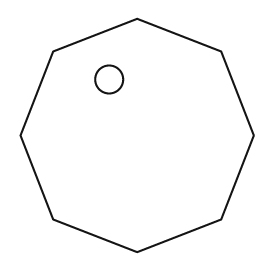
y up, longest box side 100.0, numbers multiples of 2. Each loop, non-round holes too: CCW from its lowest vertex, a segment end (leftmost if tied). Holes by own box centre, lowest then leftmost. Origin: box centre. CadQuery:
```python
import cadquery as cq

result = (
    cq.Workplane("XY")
    .moveTo(0.0, -50.0)
    .lineTo(36.0, -36.0)
    .lineTo(50.0, 0.0)
    .lineTo(36.0, 36.0)
    .lineTo(0.0, 50.0)
    .lineTo(-36.0, 36.0)
    .lineTo(-50.0, 0.0)
    .lineTo(-36.0, -36.0)
    .close()
    .moveTo(-12.0, 24.0)
    .circle(6.0)
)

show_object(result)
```